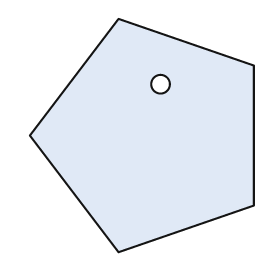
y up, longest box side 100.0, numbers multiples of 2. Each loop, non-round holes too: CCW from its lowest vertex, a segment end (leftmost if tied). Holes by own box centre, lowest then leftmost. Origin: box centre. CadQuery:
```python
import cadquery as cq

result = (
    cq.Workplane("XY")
    .moveTo(-10.0, -50.0)
    .lineTo(48.0, -30.0)
    .lineTo(48.0, 30.0)
    .lineTo(-10.0, 50.0)
    .lineTo(-48.0, 0.0)
    .close()
    .moveTo(8.0, 22.0)
    .circle(4.0)
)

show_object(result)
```